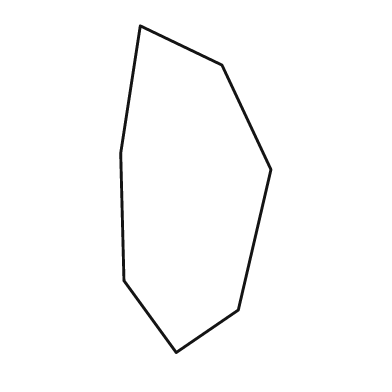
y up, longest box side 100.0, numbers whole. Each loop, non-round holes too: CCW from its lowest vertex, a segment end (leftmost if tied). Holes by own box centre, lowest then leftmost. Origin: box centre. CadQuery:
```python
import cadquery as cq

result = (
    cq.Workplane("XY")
    .moveTo(-6.0, -50.0)
    .lineTo(13.0, -37.0)
    .lineTo(23.0, 6.0)
    .lineTo(8.0, 38.0)
    .lineTo(-17.0, 50.0)
    .lineTo(-23.0, 11.0)
    .lineTo(-22.0, -28.0)
    .close()
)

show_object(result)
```